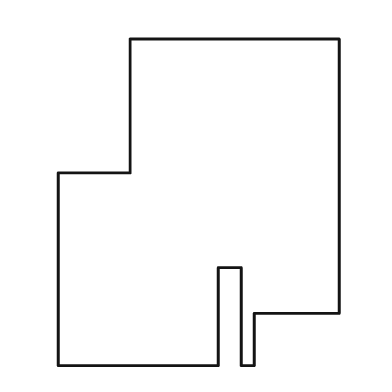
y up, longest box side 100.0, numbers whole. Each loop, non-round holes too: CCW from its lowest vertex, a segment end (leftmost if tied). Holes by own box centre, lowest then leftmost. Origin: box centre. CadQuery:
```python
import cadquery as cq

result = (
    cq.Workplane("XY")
    .moveTo(-43.0, -50.0)
    .lineTo(6.0, -50.0)
    .lineTo(6.0, -20.0)
    .lineTo(13.0, -20.0)
    .lineTo(13.0, -50.0)
    .lineTo(17.0, -50.0)
    .lineTo(17.0, -34.0)
    .lineTo(43.0, -34.0)
    .lineTo(43.0, 50.0)
    .lineTo(-21.0, 50.0)
    .lineTo(-21.0, 9.0)
    .lineTo(-43.0, 9.0)
    .close()
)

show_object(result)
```